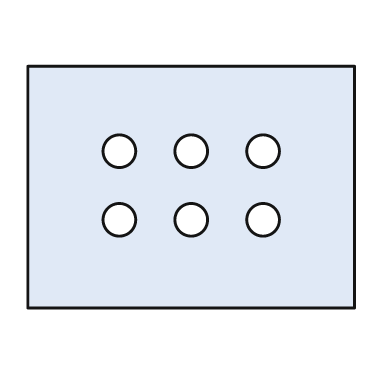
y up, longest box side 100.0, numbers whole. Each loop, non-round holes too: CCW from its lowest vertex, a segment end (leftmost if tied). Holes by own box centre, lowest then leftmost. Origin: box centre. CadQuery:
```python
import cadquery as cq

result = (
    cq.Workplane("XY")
    .moveTo(-50.0, -37.0)
    .lineTo(50.0, -37.0)
    .lineTo(50.0, 37.0)
    .lineTo(-50.0, 37.0)
    .close()
    .moveTo(-22.0, -10.0)
    .circle(5.0)
    .moveTo(0.0, -10.0)
    .circle(5.0)
    .moveTo(22.0, -10.0)
    .circle(5.0)
    .moveTo(-22.0, 11.0)
    .circle(5.0)
    .moveTo(0.0, 11.0)
    .circle(5.0)
    .moveTo(22.0, 11.0)
    .circle(5.0)
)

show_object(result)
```